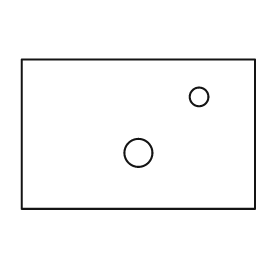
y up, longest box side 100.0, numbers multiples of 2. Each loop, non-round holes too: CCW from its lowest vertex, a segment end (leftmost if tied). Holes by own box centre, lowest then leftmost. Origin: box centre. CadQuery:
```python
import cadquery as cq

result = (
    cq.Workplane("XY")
    .moveTo(-50.0, -32.0)
    .lineTo(50.0, -32.0)
    .lineTo(50.0, 32.0)
    .lineTo(-50.0, 32.0)
    .close()
    .moveTo(0.0, -8.0)
    .circle(6.0)
    .moveTo(26.0, 16.0)
    .circle(4.0)
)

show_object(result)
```